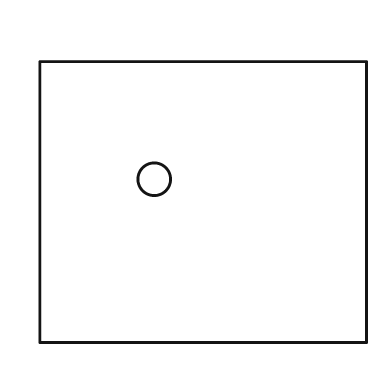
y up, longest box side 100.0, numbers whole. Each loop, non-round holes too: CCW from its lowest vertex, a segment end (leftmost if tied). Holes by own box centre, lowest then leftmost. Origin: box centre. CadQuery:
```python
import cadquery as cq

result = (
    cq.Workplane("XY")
    .moveTo(-50.0, -43.0)
    .lineTo(50.0, -43.0)
    .lineTo(50.0, 43.0)
    .lineTo(-50.0, 43.0)
    .close()
    .moveTo(-15.0, 7.0)
    .circle(5.0)
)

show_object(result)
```